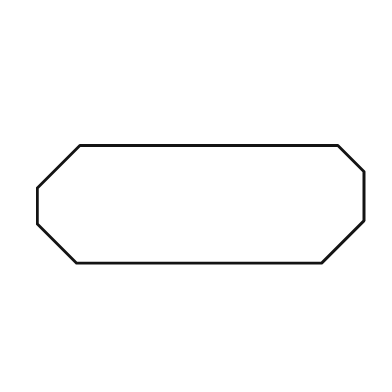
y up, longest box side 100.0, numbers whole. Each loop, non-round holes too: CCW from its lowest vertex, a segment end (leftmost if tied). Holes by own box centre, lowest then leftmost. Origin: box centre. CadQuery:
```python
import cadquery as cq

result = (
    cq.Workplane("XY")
    .moveTo(-38.0, -18.0)
    .lineTo(37.0, -18.0)
    .lineTo(50.0, -5.0)
    .lineTo(50.0, 10.0)
    .lineTo(42.0, 18.0)
    .lineTo(-37.0, 18.0)
    .lineTo(-50.0, 5.0)
    .lineTo(-50.0, -6.0)
    .close()
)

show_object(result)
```